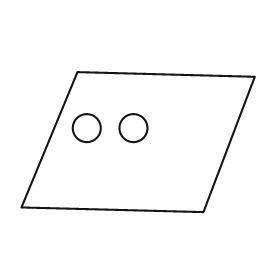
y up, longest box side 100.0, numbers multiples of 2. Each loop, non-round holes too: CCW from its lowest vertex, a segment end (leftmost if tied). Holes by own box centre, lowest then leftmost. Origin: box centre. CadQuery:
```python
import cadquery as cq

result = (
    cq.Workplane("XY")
    .moveTo(28.0, -30.0)
    .lineTo(50.0, 28.0)
    .lineTo(-26.0, 30.0)
    .lineTo(-50.0, -28.0)
    .close()
    .moveTo(-22.0, 6.0)
    .circle(6.0)
    .moveTo(-2.0, 6.0)
    .circle(6.0)
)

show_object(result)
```